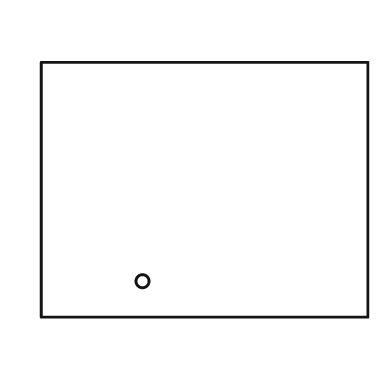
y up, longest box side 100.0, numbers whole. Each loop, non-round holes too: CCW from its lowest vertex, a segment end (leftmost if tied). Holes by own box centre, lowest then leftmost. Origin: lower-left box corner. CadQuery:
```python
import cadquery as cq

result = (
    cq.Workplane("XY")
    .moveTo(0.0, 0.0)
    .lineTo(100.0, 0.0)
    .lineTo(100.0, 78.0)
    .lineTo(0.0, 78.0)
    .close()
    .moveTo(31.0, 11.0)
    .circle(2.0)
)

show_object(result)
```